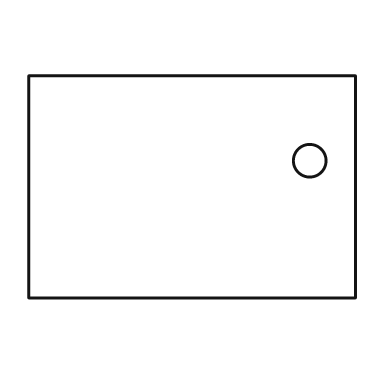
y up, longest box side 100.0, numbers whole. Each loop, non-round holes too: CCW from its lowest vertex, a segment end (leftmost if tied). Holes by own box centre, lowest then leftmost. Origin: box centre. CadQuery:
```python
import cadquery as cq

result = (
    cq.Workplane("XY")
    .moveTo(-50.0, -34.0)
    .lineTo(50.0, -34.0)
    .lineTo(50.0, 34.0)
    .lineTo(-50.0, 34.0)
    .close()
    .moveTo(36.0, 8.0)
    .circle(5.0)
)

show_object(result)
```